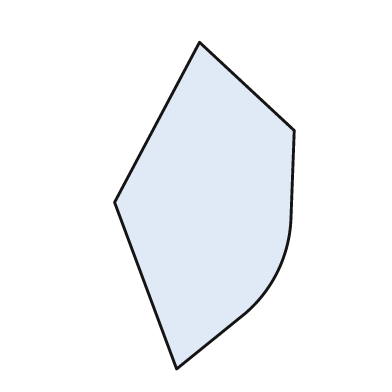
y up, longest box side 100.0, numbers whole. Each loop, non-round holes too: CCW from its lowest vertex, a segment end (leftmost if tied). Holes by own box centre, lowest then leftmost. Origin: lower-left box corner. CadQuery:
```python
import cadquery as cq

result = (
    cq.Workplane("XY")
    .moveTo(19.0, 0.0)
    .lineTo(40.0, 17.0)
    .threePointArc((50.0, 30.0), (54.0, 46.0))
    .lineTo(55.0, 73.0)
    .lineTo(26.0, 100.0)
    .lineTo(0.0, 51.0)
    .close()
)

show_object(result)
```